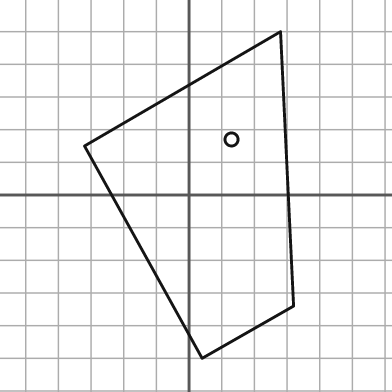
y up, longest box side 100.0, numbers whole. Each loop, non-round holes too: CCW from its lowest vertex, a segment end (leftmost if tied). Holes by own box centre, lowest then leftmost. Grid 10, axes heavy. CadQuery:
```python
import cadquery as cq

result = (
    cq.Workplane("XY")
    .moveTo(4.0, -50.0)
    .lineTo(32.0, -34.0)
    .lineTo(28.0, 50.0)
    .lineTo(-32.0, 15.0)
    .close()
    .moveTo(13.0, 17.0)
    .circle(2.0)
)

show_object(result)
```